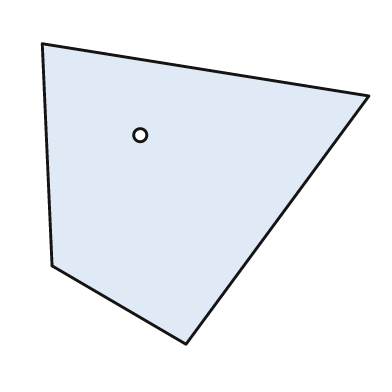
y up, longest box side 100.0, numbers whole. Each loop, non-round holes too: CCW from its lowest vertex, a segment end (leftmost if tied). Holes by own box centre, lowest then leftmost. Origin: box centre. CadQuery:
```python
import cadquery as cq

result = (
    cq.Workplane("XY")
    .moveTo(-6.0, -46.0)
    .lineTo(50.0, 30.0)
    .lineTo(-50.0, 46.0)
    .lineTo(-47.0, -22.0)
    .close()
    .moveTo(-20.0, 18.0)
    .circle(2.0)
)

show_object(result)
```